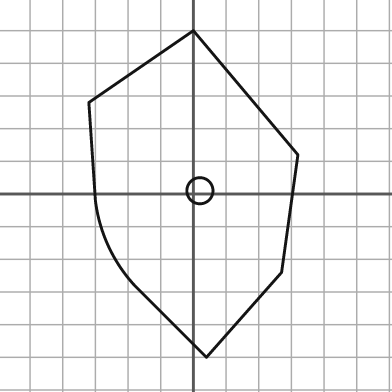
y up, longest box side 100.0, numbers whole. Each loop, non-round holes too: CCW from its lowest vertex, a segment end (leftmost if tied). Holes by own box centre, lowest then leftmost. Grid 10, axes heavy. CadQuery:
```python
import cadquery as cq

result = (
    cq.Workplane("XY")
    .moveTo(4.0, -50.0)
    .lineTo(27.0, -24.0)
    .lineTo(32.0, 12.0)
    .lineTo(0.0, 50.0)
    .lineTo(-32.0, 28.0)
    .lineTo(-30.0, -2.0)
    .threePointArc((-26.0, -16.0), (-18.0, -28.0))
    .close()
    .moveTo(2.0, 1.0)
    .circle(4.0)
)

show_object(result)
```